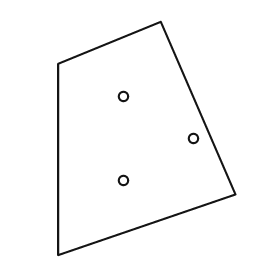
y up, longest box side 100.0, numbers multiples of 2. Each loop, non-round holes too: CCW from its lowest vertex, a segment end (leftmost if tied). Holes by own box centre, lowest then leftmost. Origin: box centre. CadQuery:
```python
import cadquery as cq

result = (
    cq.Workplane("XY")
    .moveTo(-38.0, -50.0)
    .lineTo(38.0, -24.0)
    .lineTo(6.0, 50.0)
    .lineTo(-38.0, 32.0)
    .close()
    .moveTo(-10.0, -18.0)
    .circle(2.0)
    .moveTo(20.0, 0.0)
    .circle(2.0)
    .moveTo(-10.0, 18.0)
    .circle(2.0)
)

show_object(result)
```